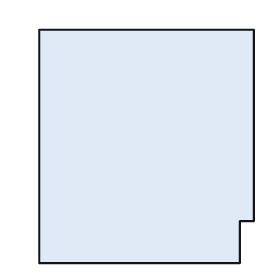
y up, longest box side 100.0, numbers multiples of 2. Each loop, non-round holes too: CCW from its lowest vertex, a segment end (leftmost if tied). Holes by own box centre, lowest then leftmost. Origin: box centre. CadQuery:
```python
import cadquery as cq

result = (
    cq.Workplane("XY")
    .moveTo(-46.0, -50.0)
    .lineTo(40.0, -50.0)
    .lineTo(40.0, -32.0)
    .lineTo(46.0, -32.0)
    .lineTo(46.0, 50.0)
    .lineTo(-46.0, 50.0)
    .close()
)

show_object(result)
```